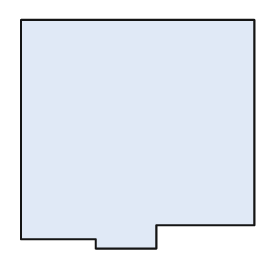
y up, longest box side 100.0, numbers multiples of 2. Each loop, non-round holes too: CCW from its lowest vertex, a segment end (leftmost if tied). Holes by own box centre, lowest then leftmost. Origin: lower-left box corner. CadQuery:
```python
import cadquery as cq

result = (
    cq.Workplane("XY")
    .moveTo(32.0, 0.0)
    .lineTo(58.0, 0.0)
    .lineTo(58.0, 10.0)
    .lineTo(100.0, 10.0)
    .lineTo(100.0, 98.0)
    .lineTo(0.0, 98.0)
    .lineTo(0.0, 4.0)
    .lineTo(32.0, 4.0)
    .close()
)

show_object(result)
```